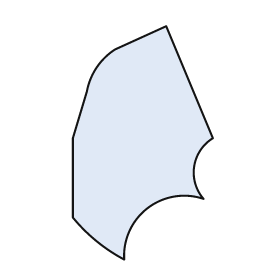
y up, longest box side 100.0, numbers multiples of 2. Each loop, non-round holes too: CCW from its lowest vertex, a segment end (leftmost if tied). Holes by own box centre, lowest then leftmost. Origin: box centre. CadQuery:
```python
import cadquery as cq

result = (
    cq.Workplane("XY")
    .moveTo(-8.0, -50.0)
    .threePointArc((2.0, -28.0), (26.0, -24.0))
    .threePointArc((22.0, -10.0), (30.0, 2.0))
    .lineTo(10.0, 50.0)
    .lineTo(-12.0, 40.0)
    .threePointArc((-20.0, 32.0), (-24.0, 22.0))
    .lineTo(-30.0, 2.0)
    .lineTo(-30.0, -32.0)
    .threePointArc((-20.0, -42.0), (-8.0, -50.0))
    .close()
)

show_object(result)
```